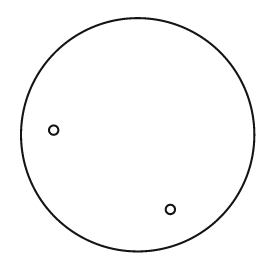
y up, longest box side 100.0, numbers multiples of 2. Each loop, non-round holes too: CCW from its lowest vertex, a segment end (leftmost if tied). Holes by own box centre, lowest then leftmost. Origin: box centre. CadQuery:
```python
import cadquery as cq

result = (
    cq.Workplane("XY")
    .moveTo(0.0, 0.0)
    .circle(50.0)
    .moveTo(14.0, -32.0)
    .circle(2.0)
    .moveTo(-36.0, 2.0)
    .circle(2.0)
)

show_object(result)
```